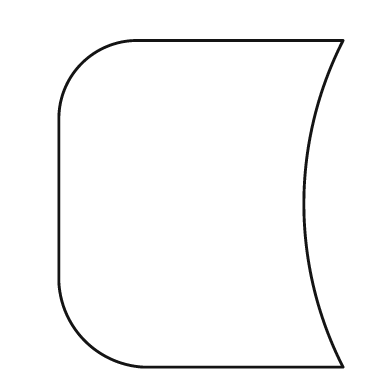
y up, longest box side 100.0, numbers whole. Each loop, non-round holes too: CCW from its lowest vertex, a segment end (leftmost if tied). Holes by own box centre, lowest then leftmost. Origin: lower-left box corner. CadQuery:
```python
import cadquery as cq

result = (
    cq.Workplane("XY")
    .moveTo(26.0, 0.0)
    .lineTo(87.0, 0.0)
    .threePointArc((75.0, 50.0), (87.0, 100.0))
    .lineTo(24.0, 100.0)
    .threePointArc((7.0, 93.0), (0.0, 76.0))
    .lineTo(0.0, 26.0)
    .threePointArc((8.0, 8.0), (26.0, 0.0))
    .close()
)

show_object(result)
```